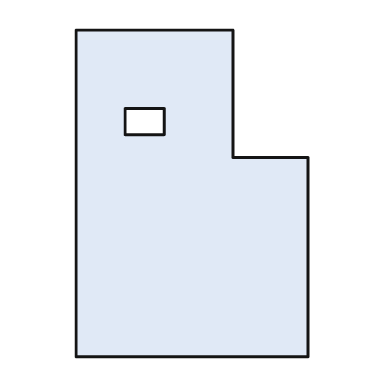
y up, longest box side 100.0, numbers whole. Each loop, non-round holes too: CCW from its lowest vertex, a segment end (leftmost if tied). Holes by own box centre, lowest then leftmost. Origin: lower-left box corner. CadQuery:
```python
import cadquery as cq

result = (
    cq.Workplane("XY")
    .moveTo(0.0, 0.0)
    .lineTo(71.0, 0.0)
    .lineTo(71.0, 61.0)
    .lineTo(48.0, 61.0)
    .lineTo(48.0, 100.0)
    .lineTo(0.0, 100.0)
    .close()
    .moveTo(15.0, 68.0)
    .lineTo(27.0, 68.0)
    .lineTo(27.0, 76.0)
    .lineTo(15.0, 76.0)
    .close()
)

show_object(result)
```